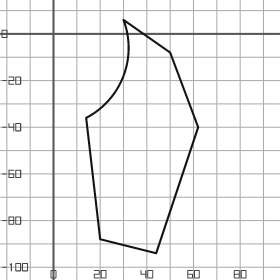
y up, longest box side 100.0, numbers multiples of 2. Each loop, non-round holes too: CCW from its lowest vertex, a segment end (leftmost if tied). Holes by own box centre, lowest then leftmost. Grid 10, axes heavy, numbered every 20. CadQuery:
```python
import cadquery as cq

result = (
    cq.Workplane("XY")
    .moveTo(44.0, -94.0)
    .lineTo(62.0, -40.0)
    .lineTo(50.0, -8.0)
    .lineTo(30.0, 6.0)
    .threePointArc((30.0, -18.0), (14.0, -36.0))
    .lineTo(20.0, -88.0)
    .close()
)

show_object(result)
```